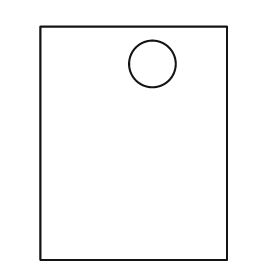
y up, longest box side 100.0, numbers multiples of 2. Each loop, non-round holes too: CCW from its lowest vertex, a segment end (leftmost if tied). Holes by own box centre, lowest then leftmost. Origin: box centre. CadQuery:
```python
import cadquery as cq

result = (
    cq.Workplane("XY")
    .moveTo(-40.0, -50.0)
    .lineTo(40.0, -50.0)
    .lineTo(40.0, 50.0)
    .lineTo(-40.0, 50.0)
    .close()
    .moveTo(8.0, 34.0)
    .circle(10.0)
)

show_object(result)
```